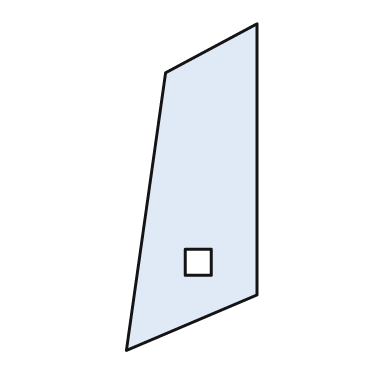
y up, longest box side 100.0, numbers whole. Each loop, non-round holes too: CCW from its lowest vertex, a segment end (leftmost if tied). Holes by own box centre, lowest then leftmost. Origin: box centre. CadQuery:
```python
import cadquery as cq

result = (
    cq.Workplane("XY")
    .moveTo(-20.0, -50.0)
    .lineTo(20.0, -33.0)
    .lineTo(20.0, 50.0)
    .lineTo(-8.0, 35.0)
    .close()
    .moveTo(-2.0, -27.0)
    .lineTo(6.0, -27.0)
    .lineTo(6.0, -19.0)
    .lineTo(-2.0, -19.0)
    .close()
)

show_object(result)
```